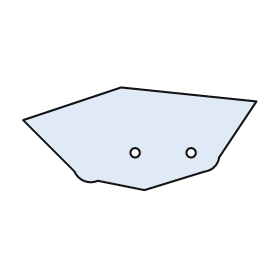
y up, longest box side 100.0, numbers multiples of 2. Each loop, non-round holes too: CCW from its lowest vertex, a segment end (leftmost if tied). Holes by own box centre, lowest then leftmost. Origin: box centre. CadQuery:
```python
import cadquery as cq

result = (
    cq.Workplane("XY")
    .moveTo(2.0, -22.0)
    .lineTo(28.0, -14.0)
    .threePointArc((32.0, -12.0), (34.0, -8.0))
    .lineTo(50.0, 16.0)
    .lineTo(-8.0, 22.0)
    .lineTo(-50.0, 8.0)
    .lineTo(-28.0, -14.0)
    .threePointArc((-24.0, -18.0), (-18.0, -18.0))
    .close()
    .moveTo(-2.0, -6.0)
    .circle(2.0)
    .moveTo(22.0, -6.0)
    .circle(2.0)
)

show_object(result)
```